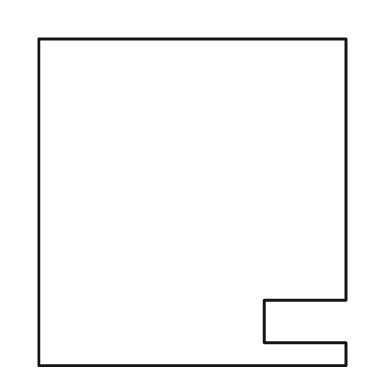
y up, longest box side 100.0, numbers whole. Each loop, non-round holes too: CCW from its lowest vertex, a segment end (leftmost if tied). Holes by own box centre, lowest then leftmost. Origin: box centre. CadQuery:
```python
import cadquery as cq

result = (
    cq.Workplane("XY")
    .moveTo(-47.0, -50.0)
    .lineTo(47.0, -50.0)
    .lineTo(47.0, -43.0)
    .lineTo(22.0, -43.0)
    .lineTo(22.0, -30.0)
    .lineTo(47.0, -30.0)
    .lineTo(47.0, 50.0)
    .lineTo(-47.0, 50.0)
    .close()
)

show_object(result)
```